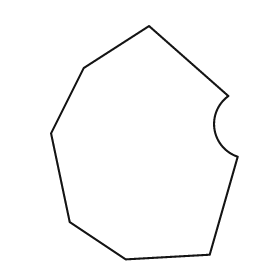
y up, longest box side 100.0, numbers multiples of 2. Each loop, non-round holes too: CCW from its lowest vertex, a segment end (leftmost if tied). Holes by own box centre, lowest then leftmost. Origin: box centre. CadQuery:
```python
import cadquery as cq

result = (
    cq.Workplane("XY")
    .moveTo(-8.0, -50.0)
    .lineTo(28.0, -48.0)
    .lineTo(40.0, -6.0)
    .threePointArc((30.0, 6.0), (36.0, 20.0))
    .lineTo(2.0, 50.0)
    .lineTo(-26.0, 32.0)
    .lineTo(-40.0, 4.0)
    .lineTo(-32.0, -34.0)
    .close()
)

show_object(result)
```